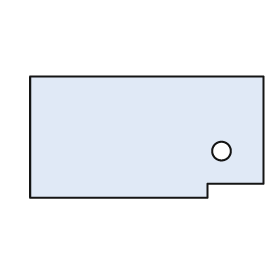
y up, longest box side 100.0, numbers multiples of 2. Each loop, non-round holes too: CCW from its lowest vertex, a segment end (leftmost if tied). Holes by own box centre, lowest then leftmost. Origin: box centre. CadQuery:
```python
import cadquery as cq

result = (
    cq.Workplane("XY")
    .moveTo(-50.0, -26.0)
    .lineTo(26.0, -26.0)
    .lineTo(26.0, -20.0)
    .lineTo(50.0, -20.0)
    .lineTo(50.0, 26.0)
    .lineTo(-50.0, 26.0)
    .close()
    .moveTo(32.0, -6.0)
    .circle(4.0)
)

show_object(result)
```